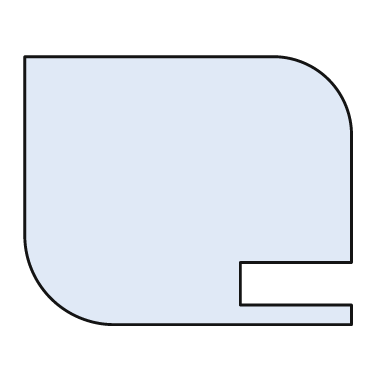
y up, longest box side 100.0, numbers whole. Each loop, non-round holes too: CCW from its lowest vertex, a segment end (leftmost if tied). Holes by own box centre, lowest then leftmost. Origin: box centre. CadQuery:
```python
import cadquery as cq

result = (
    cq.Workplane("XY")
    .moveTo(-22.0, -41.0)
    .lineTo(50.0, -41.0)
    .lineTo(50.0, -35.0)
    .lineTo(16.0, -35.0)
    .lineTo(16.0, -22.0)
    .lineTo(50.0, -22.0)
    .lineTo(50.0, 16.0)
    .threePointArc((43.0, 34.0), (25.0, 41.0))
    .lineTo(-50.0, 41.0)
    .lineTo(-50.0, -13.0)
    .threePointArc((-42.0, -33.0), (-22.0, -41.0))
    .close()
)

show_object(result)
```